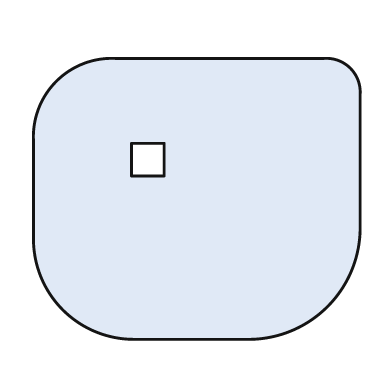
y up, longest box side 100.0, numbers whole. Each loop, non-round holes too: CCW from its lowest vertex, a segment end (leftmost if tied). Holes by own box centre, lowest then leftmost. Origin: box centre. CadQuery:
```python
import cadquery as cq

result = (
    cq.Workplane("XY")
    .moveTo(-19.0, -43.0)
    .lineTo(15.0, -43.0)
    .threePointArc((40.0, -33.0), (50.0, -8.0))
    .lineTo(50.0, 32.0)
    .threePointArc((47.0, 40.0), (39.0, 43.0))
    .lineTo(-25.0, 43.0)
    .threePointArc((-43.0, 36.0), (-50.0, 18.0))
    .lineTo(-50.0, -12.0)
    .threePointArc((-41.0, -34.0), (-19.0, -43.0))
    .close()
    .moveTo(-20.0, 7.0)
    .lineTo(-10.0, 7.0)
    .lineTo(-10.0, 17.0)
    .lineTo(-20.0, 17.0)
    .close()
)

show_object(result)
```